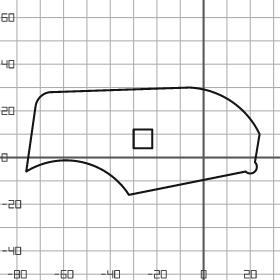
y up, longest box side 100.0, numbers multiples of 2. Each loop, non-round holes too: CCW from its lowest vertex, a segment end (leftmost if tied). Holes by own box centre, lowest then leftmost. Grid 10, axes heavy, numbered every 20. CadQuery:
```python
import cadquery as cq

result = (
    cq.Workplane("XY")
    .moveTo(-32.0, -16.0)
    .lineTo(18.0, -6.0)
    .threePointArc((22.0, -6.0), (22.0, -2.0))
    .lineTo(24.0, 10.0)
    .threePointArc((12.0, 24.0), (-6.0, 30.0))
    .lineTo(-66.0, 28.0)
    .threePointArc((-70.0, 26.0), (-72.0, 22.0))
    .lineTo(-76.0, -6.0)
    .threePointArc((-52.0, -2.0), (-32.0, -16.0))
    .close()
    .moveTo(-30.0, 4.0)
    .lineTo(-22.0, 4.0)
    .lineTo(-22.0, 12.0)
    .lineTo(-30.0, 12.0)
    .close()
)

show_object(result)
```